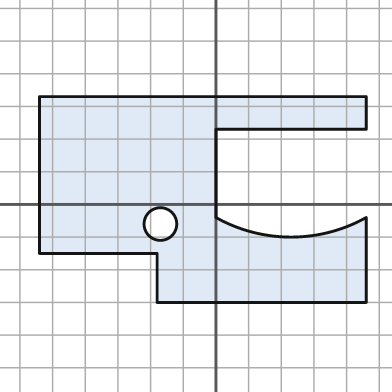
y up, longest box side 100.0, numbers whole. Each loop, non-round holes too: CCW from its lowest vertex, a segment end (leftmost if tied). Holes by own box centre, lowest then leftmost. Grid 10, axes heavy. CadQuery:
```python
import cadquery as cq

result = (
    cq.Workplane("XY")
    .moveTo(-18.0, -30.0)
    .lineTo(46.0, -30.0)
    .lineTo(46.0, -4.0)
    .threePointArc((23.0, -10.0), (0.0, -4.0))
    .lineTo(0.0, 23.0)
    .lineTo(46.0, 23.0)
    .lineTo(46.0, 33.0)
    .lineTo(-54.0, 33.0)
    .lineTo(-54.0, -15.0)
    .lineTo(-18.0, -15.0)
    .close()
    .moveTo(-17.0, -6.0)
    .circle(5.0)
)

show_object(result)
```